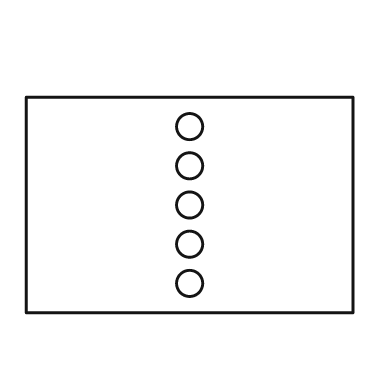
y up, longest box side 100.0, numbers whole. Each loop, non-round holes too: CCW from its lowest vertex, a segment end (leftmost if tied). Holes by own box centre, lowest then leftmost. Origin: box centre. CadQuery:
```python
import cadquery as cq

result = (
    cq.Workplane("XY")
    .moveTo(-50.0, -33.0)
    .lineTo(50.0, -33.0)
    .lineTo(50.0, 33.0)
    .lineTo(-50.0, 33.0)
    .close()
    .moveTo(0.0, -24.0)
    .circle(4.0)
    .moveTo(0.0, -12.0)
    .circle(4.0)
    .moveTo(0.0, 0.0)
    .circle(4.0)
    .moveTo(0.0, 12.0)
    .circle(4.0)
    .moveTo(0.0, 24.0)
    .circle(4.0)
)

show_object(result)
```